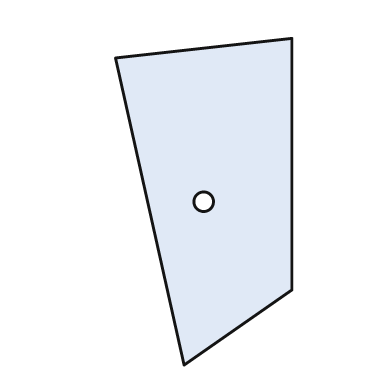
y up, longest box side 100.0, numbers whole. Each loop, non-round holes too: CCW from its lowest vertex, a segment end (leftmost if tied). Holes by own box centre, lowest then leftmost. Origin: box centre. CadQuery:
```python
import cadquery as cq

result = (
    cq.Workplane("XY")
    .moveTo(-6.0, -50.0)
    .lineTo(27.0, -27.0)
    .lineTo(27.0, 50.0)
    .lineTo(-27.0, 44.0)
    .close()
    .moveTo(0.0, 0.0)
    .circle(3.0)
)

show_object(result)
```